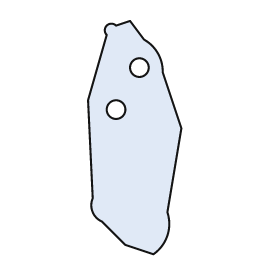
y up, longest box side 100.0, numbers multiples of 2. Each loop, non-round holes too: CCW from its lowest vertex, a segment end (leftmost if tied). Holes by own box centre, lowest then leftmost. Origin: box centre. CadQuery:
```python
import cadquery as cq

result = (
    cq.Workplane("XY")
    .moveTo(8.0, -50.0)
    .threePointArc((14.0, -42.0), (14.0, -32.0))
    .lineTo(20.0, 4.0)
    .lineTo(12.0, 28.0)
    .threePointArc((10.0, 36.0), (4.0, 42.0))
    .lineTo(-2.0, 50.0)
    .lineTo(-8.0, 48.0)
    .threePointArc((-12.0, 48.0), (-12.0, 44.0))
    .lineTo(-20.0, 16.0)
    .lineTo(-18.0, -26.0)
    .threePointArc((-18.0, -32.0), (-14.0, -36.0))
    .lineTo(-4.0, -46.0)
    .close()
    .moveTo(-8.0, 12.0)
    .circle(4.0)
    .moveTo(2.0, 30.0)
    .circle(4.0)
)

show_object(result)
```